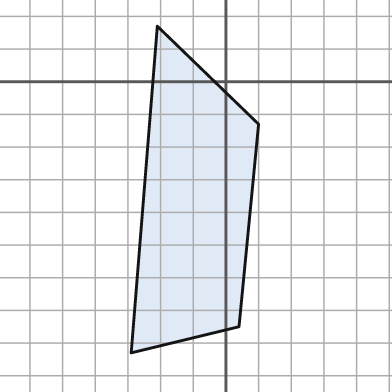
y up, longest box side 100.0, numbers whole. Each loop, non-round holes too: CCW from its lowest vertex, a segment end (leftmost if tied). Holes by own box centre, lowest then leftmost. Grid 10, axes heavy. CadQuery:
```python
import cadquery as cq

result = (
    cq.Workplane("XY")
    .moveTo(-29.0, -83.0)
    .lineTo(4.0, -75.0)
    .lineTo(10.0, -13.0)
    .lineTo(-21.0, 17.0)
    .close()
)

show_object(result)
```